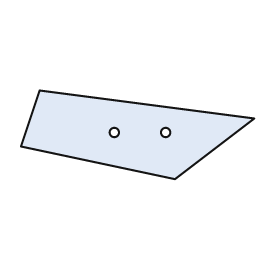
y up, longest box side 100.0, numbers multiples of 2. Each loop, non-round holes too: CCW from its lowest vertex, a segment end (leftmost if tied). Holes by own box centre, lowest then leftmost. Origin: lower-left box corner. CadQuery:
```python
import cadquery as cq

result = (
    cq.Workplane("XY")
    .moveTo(66.0, 0.0)
    .lineTo(100.0, 26.0)
    .lineTo(8.0, 38.0)
    .lineTo(0.0, 14.0)
    .close()
    .moveTo(40.0, 20.0)
    .circle(2.0)
    .moveTo(62.0, 20.0)
    .circle(2.0)
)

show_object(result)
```